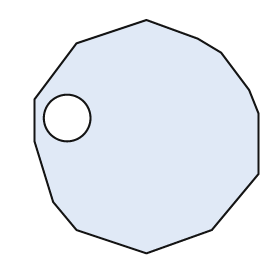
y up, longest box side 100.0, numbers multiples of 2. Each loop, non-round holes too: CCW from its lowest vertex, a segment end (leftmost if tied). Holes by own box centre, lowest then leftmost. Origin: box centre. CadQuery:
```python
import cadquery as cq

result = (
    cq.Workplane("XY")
    .moveTo(0.0, -50.0)
    .lineTo(28.0, -40.0)
    .lineTo(48.0, -16.0)
    .lineTo(48.0, 10.0)
    .lineTo(44.0, 20.0)
    .lineTo(32.0, 36.0)
    .lineTo(22.0, 42.0)
    .lineTo(0.0, 50.0)
    .lineTo(-30.0, 40.0)
    .lineTo(-48.0, 16.0)
    .lineTo(-48.0, -2.0)
    .lineTo(-40.0, -28.0)
    .lineTo(-30.0, -40.0)
    .close()
    .moveTo(-34.0, 8.0)
    .circle(10.0)
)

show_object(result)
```